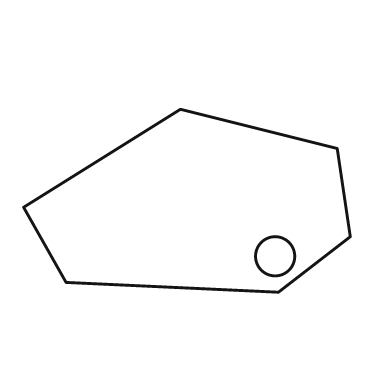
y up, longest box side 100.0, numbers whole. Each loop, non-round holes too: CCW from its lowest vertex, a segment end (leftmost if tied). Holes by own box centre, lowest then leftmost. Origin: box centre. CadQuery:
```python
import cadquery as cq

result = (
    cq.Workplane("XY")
    .moveTo(28.0, -28.0)
    .lineTo(50.0, -11.0)
    .lineTo(46.0, 16.0)
    .lineTo(-2.0, 28.0)
    .lineTo(-50.0, -2.0)
    .lineTo(-37.0, -25.0)
    .close()
    .moveTo(27.0, -17.0)
    .circle(6.0)
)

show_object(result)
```